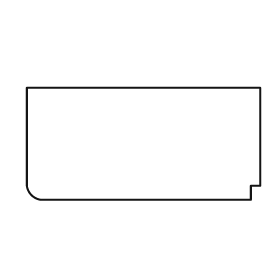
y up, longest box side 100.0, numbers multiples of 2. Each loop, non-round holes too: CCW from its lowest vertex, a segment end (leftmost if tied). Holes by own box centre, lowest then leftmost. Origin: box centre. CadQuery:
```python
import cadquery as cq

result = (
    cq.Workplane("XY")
    .moveTo(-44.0, -24.0)
    .lineTo(46.0, -24.0)
    .lineTo(46.0, -18.0)
    .lineTo(50.0, -18.0)
    .lineTo(50.0, 24.0)
    .lineTo(-50.0, 24.0)
    .lineTo(-50.0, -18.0)
    .threePointArc((-48.0, -22.0), (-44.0, -24.0))
    .close()
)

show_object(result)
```